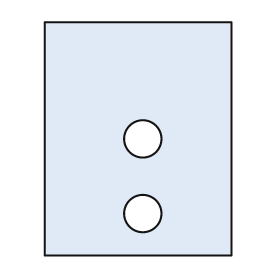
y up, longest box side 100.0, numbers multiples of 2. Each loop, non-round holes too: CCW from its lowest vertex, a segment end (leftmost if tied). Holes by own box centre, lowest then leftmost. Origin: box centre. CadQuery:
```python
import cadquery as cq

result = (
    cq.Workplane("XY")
    .moveTo(-40.0, -50.0)
    .lineTo(40.0, -50.0)
    .lineTo(40.0, 50.0)
    .lineTo(-40.0, 50.0)
    .close()
    .moveTo(2.0, -32.0)
    .circle(8.0)
    .moveTo(2.0, 0.0)
    .circle(8.0)
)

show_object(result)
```